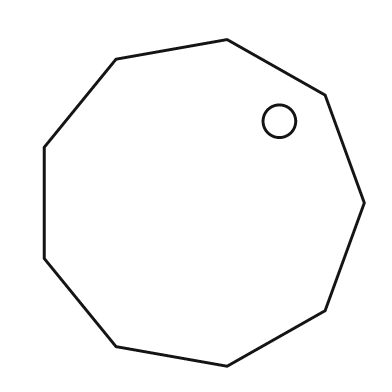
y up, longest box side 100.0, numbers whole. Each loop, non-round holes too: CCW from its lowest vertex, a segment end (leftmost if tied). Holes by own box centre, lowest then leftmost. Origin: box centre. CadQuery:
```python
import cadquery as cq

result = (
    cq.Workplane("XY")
    .moveTo(7.0, -50.0)
    .lineTo(37.0, -33.0)
    .lineTo(49.0, 0.0)
    .lineTo(37.0, 33.0)
    .lineTo(7.0, 50.0)
    .lineTo(-27.0, 44.0)
    .lineTo(-49.0, 17.0)
    .lineTo(-49.0, -17.0)
    .lineTo(-27.0, -44.0)
    .close()
    .moveTo(23.0, 25.0)
    .circle(5.0)
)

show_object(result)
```